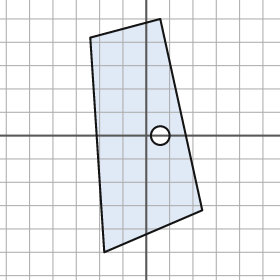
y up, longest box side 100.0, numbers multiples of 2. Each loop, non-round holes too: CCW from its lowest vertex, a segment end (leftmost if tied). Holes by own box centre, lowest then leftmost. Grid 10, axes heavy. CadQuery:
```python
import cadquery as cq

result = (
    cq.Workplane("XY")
    .moveTo(-18.0, -50.0)
    .lineTo(24.0, -32.0)
    .lineTo(6.0, 50.0)
    .lineTo(-24.0, 42.0)
    .close()
    .moveTo(6.0, 0.0)
    .circle(4.0)
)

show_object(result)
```